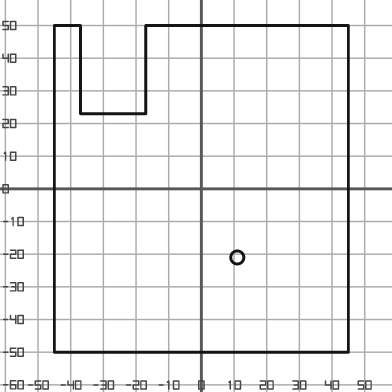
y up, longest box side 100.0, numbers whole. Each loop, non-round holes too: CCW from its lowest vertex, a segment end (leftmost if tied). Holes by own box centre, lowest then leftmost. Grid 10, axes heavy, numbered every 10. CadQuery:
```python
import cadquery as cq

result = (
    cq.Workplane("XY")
    .moveTo(-45.0, -50.0)
    .lineTo(45.0, -50.0)
    .lineTo(45.0, 50.0)
    .lineTo(-17.0, 50.0)
    .lineTo(-17.0, 23.0)
    .lineTo(-37.0, 23.0)
    .lineTo(-37.0, 50.0)
    .lineTo(-45.0, 50.0)
    .close()
    .moveTo(11.0, -21.0)
    .circle(2.0)
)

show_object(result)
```